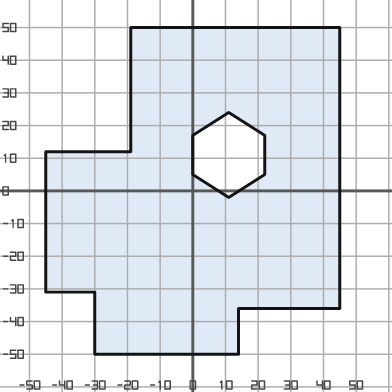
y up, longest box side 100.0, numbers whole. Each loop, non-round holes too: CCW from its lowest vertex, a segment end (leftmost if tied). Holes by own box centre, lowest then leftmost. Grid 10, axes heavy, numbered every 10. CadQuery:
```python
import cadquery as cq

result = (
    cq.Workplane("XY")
    .moveTo(-30.0, -50.0)
    .lineTo(14.0, -50.0)
    .lineTo(14.0, -36.0)
    .lineTo(45.0, -36.0)
    .lineTo(45.0, 50.0)
    .lineTo(-19.0, 50.0)
    .lineTo(-19.0, 12.0)
    .lineTo(-45.0, 12.0)
    .lineTo(-45.0, -31.0)
    .lineTo(-30.0, -31.0)
    .close()
    .moveTo(11.0, -2.0)
    .lineTo(22.0, 5.0)
    .lineTo(22.0, 17.0)
    .lineTo(11.0, 24.0)
    .lineTo(0.0, 17.0)
    .lineTo(0.0, 5.0)
    .close()
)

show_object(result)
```